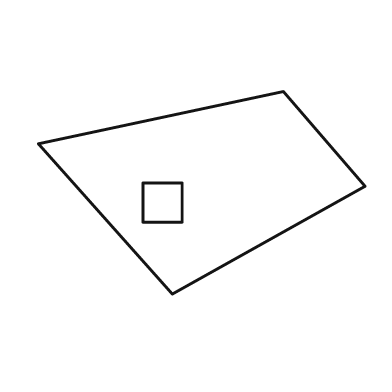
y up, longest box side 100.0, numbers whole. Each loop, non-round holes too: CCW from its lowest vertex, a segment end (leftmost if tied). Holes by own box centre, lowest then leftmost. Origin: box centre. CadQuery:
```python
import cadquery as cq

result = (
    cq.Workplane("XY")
    .moveTo(-9.0, -31.0)
    .lineTo(50.0, 2.0)
    .lineTo(25.0, 31.0)
    .lineTo(-50.0, 15.0)
    .close()
    .moveTo(-18.0, -9.0)
    .lineTo(-6.0, -9.0)
    .lineTo(-6.0, 3.0)
    .lineTo(-18.0, 3.0)
    .close()
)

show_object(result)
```